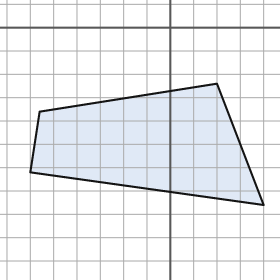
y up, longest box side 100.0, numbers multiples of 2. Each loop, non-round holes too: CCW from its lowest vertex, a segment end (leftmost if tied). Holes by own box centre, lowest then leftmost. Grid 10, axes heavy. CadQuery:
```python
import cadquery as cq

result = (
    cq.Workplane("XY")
    .moveTo(40.0, -76.0)
    .lineTo(20.0, -24.0)
    .lineTo(-56.0, -36.0)
    .lineTo(-60.0, -62.0)
    .close()
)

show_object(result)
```